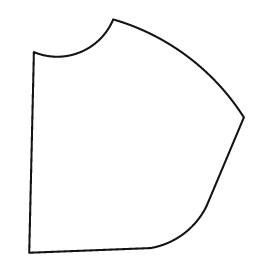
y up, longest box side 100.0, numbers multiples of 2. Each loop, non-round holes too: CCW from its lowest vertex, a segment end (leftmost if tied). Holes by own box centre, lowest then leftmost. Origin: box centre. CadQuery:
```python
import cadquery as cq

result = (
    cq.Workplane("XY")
    .moveTo(-46.0, -50.0)
    .lineTo(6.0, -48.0)
    .threePointArc((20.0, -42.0), (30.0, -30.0))
    .lineTo(46.0, 8.0)
    .threePointArc((22.0, 34.0), (-10.0, 50.0))
    .threePointArc((-24.0, 36.0), (-44.0, 36.0))
    .close()
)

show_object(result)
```